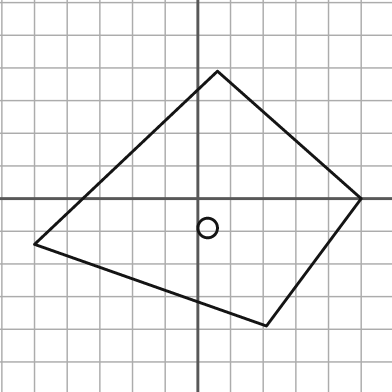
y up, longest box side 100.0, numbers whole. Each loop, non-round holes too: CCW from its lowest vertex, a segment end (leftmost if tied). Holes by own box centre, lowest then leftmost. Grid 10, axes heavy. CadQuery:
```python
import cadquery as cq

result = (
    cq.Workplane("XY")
    .moveTo(21.0, -39.0)
    .lineTo(50.0, 0.0)
    .lineTo(6.0, 39.0)
    .lineTo(-50.0, -14.0)
    .close()
    .moveTo(3.0, -9.0)
    .circle(3.0)
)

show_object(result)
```